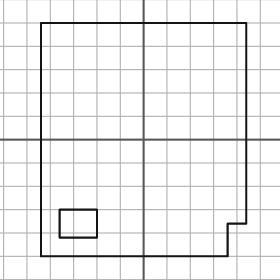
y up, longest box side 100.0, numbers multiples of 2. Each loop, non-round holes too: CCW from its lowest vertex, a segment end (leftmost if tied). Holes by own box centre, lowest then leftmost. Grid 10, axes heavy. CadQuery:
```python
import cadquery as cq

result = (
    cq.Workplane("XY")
    .moveTo(-44.0, -50.0)
    .lineTo(36.0, -50.0)
    .lineTo(36.0, -36.0)
    .lineTo(44.0, -36.0)
    .lineTo(44.0, 50.0)
    .lineTo(-44.0, 50.0)
    .close()
    .moveTo(-36.0, -42.0)
    .lineTo(-20.0, -42.0)
    .lineTo(-20.0, -30.0)
    .lineTo(-36.0, -30.0)
    .close()
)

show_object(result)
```